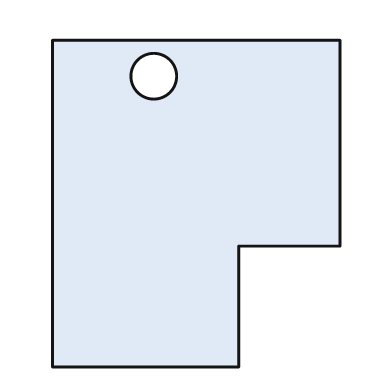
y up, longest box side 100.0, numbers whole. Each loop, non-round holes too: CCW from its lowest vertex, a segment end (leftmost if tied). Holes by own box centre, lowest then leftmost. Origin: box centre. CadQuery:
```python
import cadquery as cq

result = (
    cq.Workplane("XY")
    .moveTo(-44.0, -50.0)
    .lineTo(13.0, -50.0)
    .lineTo(13.0, -13.0)
    .lineTo(44.0, -13.0)
    .lineTo(44.0, 50.0)
    .lineTo(-44.0, 50.0)
    .close()
    .moveTo(-13.0, 39.0)
    .circle(7.0)
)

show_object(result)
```